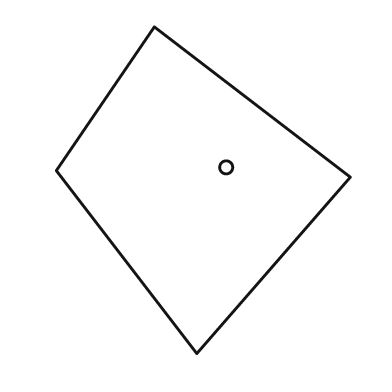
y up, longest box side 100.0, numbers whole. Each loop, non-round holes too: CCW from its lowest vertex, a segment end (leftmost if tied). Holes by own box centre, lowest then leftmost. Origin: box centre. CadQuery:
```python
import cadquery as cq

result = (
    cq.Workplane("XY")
    .moveTo(-2.0, -50.0)
    .lineTo(45.0, 4.0)
    .lineTo(-15.0, 50.0)
    .lineTo(-45.0, 6.0)
    .close()
    .moveTo(7.0, 7.0)
    .circle(2.0)
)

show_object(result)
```